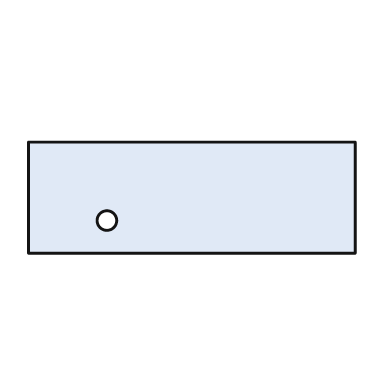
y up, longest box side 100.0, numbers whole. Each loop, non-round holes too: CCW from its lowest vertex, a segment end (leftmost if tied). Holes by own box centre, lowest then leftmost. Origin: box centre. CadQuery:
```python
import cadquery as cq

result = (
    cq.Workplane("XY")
    .moveTo(-50.0, -17.0)
    .lineTo(50.0, -17.0)
    .lineTo(50.0, 17.0)
    .lineTo(-50.0, 17.0)
    .close()
    .moveTo(-26.0, -7.0)
    .circle(3.0)
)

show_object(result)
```